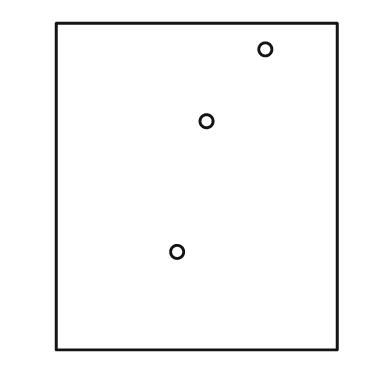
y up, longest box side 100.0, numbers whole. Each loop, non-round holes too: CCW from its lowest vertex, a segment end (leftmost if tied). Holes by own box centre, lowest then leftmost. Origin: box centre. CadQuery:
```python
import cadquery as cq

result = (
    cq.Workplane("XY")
    .moveTo(-43.0, -50.0)
    .lineTo(43.0, -50.0)
    .lineTo(43.0, 50.0)
    .lineTo(-43.0, 50.0)
    .close()
    .moveTo(-6.0, -20.0)
    .circle(2.0)
    .moveTo(3.0, 20.0)
    .circle(2.0)
    .moveTo(21.0, 42.0)
    .circle(2.0)
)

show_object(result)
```